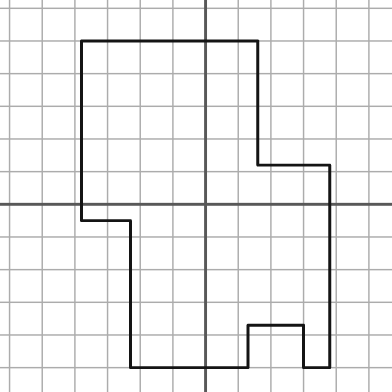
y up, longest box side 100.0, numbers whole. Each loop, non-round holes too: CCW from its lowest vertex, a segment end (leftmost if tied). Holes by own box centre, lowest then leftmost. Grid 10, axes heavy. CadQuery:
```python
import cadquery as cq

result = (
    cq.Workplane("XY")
    .moveTo(-23.0, -50.0)
    .lineTo(13.0, -50.0)
    .lineTo(13.0, -37.0)
    .lineTo(30.0, -37.0)
    .lineTo(30.0, -50.0)
    .lineTo(38.0, -50.0)
    .lineTo(38.0, 12.0)
    .lineTo(16.0, 12.0)
    .lineTo(16.0, 50.0)
    .lineTo(-38.0, 50.0)
    .lineTo(-38.0, -5.0)
    .lineTo(-23.0, -5.0)
    .close()
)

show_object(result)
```